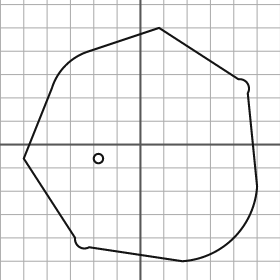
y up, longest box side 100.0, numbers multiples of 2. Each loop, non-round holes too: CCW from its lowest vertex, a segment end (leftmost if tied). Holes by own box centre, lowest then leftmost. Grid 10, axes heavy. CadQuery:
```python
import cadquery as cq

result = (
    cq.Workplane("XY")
    .moveTo(18.0, -50.0)
    .threePointArc((40.0, -40.0), (50.0, -18.0))
    .lineTo(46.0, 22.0)
    .threePointArc((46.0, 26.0), (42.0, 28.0))
    .lineTo(8.0, 50.0)
    .lineTo(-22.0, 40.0)
    .threePointArc((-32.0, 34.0), (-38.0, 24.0))
    .lineTo(-50.0, -6.0)
    .lineTo(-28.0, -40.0)
    .threePointArc((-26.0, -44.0), (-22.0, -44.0))
    .close()
    .moveTo(-18.0, -6.0)
    .circle(2.0)
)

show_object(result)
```